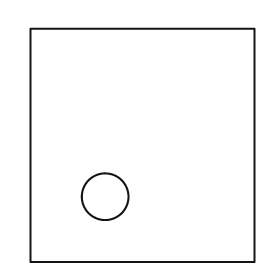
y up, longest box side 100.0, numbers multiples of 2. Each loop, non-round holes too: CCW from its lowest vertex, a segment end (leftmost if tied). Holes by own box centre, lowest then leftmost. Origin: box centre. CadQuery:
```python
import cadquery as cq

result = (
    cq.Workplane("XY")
    .moveTo(-48.0, -50.0)
    .lineTo(48.0, -50.0)
    .lineTo(48.0, 50.0)
    .lineTo(-48.0, 50.0)
    .close()
    .moveTo(-16.0, -22.0)
    .circle(10.0)
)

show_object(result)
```